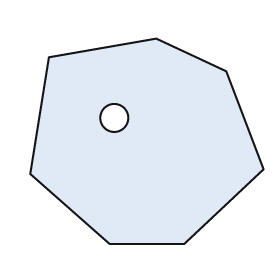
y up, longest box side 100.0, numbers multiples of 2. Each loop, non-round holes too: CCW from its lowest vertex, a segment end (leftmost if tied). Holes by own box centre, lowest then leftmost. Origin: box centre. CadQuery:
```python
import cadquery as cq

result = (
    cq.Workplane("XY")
    .moveTo(-16.0, -44.0)
    .lineTo(16.0, -44.0)
    .lineTo(50.0, -12.0)
    .lineTo(34.0, 30.0)
    .lineTo(4.0, 44.0)
    .lineTo(-42.0, 36.0)
    .lineTo(-50.0, -14.0)
    .close()
    .moveTo(-14.0, 10.0)
    .circle(6.0)
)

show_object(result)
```